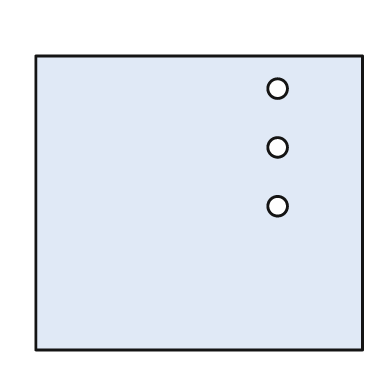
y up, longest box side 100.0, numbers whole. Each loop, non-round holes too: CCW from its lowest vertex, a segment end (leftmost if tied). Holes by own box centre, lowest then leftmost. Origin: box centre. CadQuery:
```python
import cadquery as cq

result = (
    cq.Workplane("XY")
    .moveTo(-50.0, -45.0)
    .lineTo(50.0, -45.0)
    .lineTo(50.0, 45.0)
    .lineTo(-50.0, 45.0)
    .close()
    .moveTo(24.0, -1.0)
    .circle(3.0)
    .moveTo(24.0, 17.0)
    .circle(3.0)
    .moveTo(24.0, 35.0)
    .circle(3.0)
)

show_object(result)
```